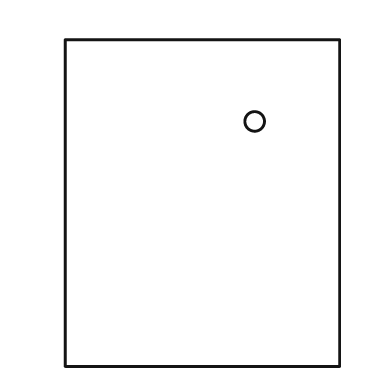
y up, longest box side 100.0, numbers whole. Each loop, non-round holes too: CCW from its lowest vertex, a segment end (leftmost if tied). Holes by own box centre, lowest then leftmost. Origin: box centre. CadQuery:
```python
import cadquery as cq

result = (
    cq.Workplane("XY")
    .moveTo(-42.0, -50.0)
    .lineTo(42.0, -50.0)
    .lineTo(42.0, 50.0)
    .lineTo(-42.0, 50.0)
    .close()
    .moveTo(16.0, 25.0)
    .circle(3.0)
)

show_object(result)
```